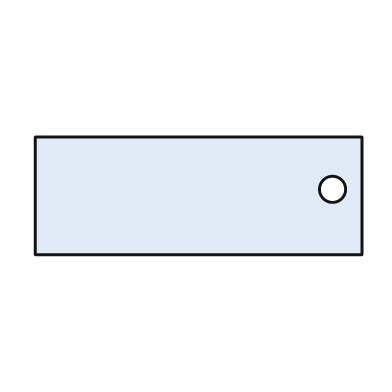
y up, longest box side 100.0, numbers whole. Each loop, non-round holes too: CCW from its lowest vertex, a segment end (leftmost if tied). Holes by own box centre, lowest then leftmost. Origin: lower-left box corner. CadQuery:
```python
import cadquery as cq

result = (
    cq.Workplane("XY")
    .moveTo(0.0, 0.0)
    .lineTo(100.0, 0.0)
    .lineTo(100.0, 36.0)
    .lineTo(0.0, 36.0)
    .close()
    .moveTo(91.0, 20.0)
    .circle(4.0)
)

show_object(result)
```